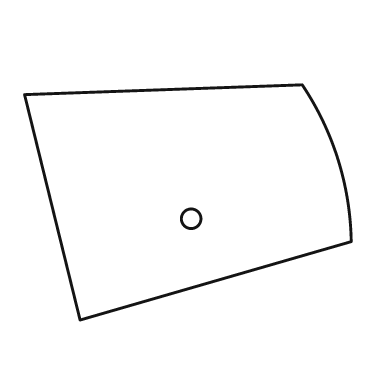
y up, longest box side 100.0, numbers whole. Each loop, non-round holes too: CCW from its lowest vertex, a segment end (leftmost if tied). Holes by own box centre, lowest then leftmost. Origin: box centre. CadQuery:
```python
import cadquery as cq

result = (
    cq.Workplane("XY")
    .moveTo(-33.0, -36.0)
    .lineTo(50.0, -12.0)
    .threePointArc((46.0, 13.0), (35.0, 36.0))
    .lineTo(-50.0, 33.0)
    .close()
    .moveTo(1.0, -5.0)
    .circle(3.0)
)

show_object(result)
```